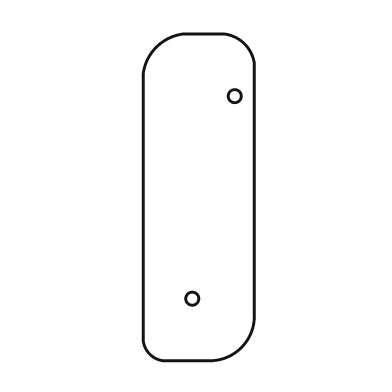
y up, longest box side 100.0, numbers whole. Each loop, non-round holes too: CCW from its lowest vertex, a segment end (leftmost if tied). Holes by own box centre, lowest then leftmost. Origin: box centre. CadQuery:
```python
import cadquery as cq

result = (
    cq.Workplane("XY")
    .moveTo(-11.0, -50.0)
    .lineTo(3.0, -50.0)
    .threePointArc((13.0, -46.0), (17.0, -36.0))
    .lineTo(17.0, 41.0)
    .threePointArc((14.0, 47.0), (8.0, 50.0))
    .lineTo(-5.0, 50.0)
    .threePointArc((-13.0, 46.0), (-17.0, 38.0))
    .lineTo(-17.0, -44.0)
    .threePointArc((-15.0, -48.0), (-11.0, -50.0))
    .close()
    .moveTo(-2.0, -31.0)
    .circle(2.0)
    .moveTo(11.0, 31.0)
    .circle(2.0)
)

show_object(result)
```